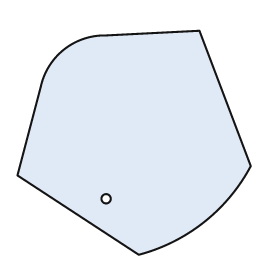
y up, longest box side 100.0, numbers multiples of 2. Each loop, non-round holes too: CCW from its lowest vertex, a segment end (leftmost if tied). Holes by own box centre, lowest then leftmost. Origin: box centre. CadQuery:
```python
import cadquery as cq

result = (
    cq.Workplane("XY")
    .moveTo(2.0, -48.0)
    .threePointArc((30.0, -34.0), (50.0, -10.0))
    .lineTo(28.0, 48.0)
    .lineTo(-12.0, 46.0)
    .threePointArc((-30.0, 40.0), (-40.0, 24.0))
    .lineTo(-50.0, -14.0)
    .close()
    .moveTo(-12.0, -24.0)
    .circle(2.0)
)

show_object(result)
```